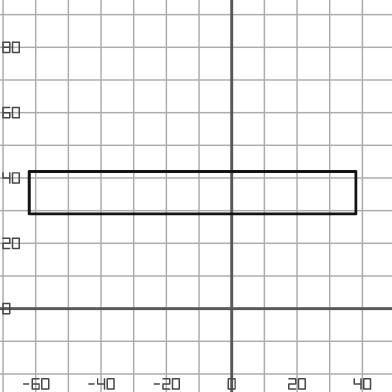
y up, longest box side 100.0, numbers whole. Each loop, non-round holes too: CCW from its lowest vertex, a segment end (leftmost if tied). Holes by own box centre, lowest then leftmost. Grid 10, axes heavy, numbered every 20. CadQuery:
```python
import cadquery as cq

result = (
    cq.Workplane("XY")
    .moveTo(-62.0, 29.0)
    .lineTo(38.0, 29.0)
    .lineTo(38.0, 42.0)
    .lineTo(-62.0, 42.0)
    .close()
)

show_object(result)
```